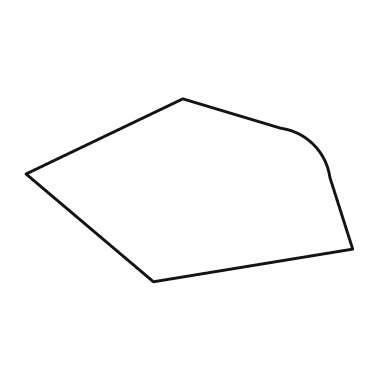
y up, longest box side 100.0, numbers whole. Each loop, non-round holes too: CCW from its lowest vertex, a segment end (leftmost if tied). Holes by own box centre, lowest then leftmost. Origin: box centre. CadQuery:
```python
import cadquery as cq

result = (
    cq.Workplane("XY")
    .moveTo(-11.0, -28.0)
    .lineTo(50.0, -18.0)
    .lineTo(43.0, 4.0)
    .threePointArc((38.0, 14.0), (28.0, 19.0))
    .lineTo(-2.0, 28.0)
    .lineTo(-50.0, 5.0)
    .close()
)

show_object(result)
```